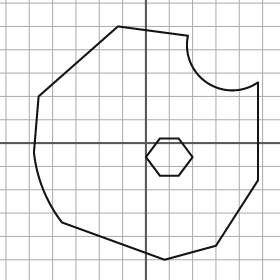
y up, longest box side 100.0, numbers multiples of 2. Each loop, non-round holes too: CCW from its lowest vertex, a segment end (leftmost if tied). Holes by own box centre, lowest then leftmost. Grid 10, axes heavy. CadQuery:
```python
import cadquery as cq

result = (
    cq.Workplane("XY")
    .moveTo(8.0, -50.0)
    .lineTo(30.0, -44.0)
    .lineTo(48.0, -16.0)
    .lineTo(48.0, 26.0)
    .threePointArc((26.0, 26.0), (18.0, 46.0))
    .lineTo(-12.0, 50.0)
    .lineTo(-46.0, 20.0)
    .lineTo(-48.0, -4.0)
    .threePointArc((-44.0, -20.0), (-36.0, -34.0))
    .close()
    .moveTo(6.0, -14.0)
    .lineTo(14.0, -14.0)
    .lineTo(20.0, -6.0)
    .lineTo(14.0, 2.0)
    .lineTo(6.0, 2.0)
    .lineTo(0.0, -6.0)
    .close()
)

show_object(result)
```